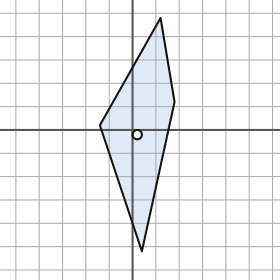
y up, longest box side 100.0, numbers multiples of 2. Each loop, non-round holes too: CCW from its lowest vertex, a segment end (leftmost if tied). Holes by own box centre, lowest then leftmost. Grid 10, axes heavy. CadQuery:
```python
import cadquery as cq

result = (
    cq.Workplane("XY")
    .moveTo(4.0, -52.0)
    .lineTo(18.0, 12.0)
    .lineTo(12.0, 48.0)
    .lineTo(-14.0, 2.0)
    .close()
    .moveTo(2.0, -2.0)
    .circle(2.0)
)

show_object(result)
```